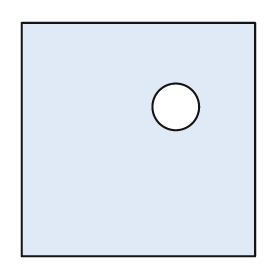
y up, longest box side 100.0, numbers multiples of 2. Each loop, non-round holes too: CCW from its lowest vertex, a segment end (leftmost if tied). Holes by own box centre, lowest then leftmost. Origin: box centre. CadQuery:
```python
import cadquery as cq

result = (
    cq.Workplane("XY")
    .moveTo(-50.0, -50.0)
    .lineTo(50.0, -50.0)
    .lineTo(50.0, 50.0)
    .lineTo(-50.0, 50.0)
    .close()
    .moveTo(16.0, 14.0)
    .circle(10.0)
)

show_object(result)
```